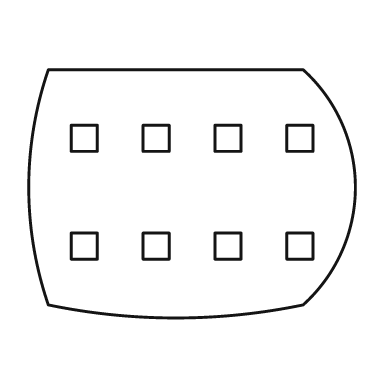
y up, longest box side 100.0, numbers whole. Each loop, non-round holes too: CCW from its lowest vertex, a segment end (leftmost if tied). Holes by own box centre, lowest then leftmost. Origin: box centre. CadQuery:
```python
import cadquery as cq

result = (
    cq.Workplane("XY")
    .moveTo(-44.0, -34.0)
    .threePointArc((-5.0, -38.0), (34.0, -34.0))
    .threePointArc((50.0, 2.0), (34.0, 38.0))
    .lineTo(-44.0, 38.0)
    .threePointArc((-50.0, 2.0), (-44.0, -34.0))
    .close()
    .moveTo(-37.0, -20.0)
    .lineTo(-29.0, -20.0)
    .lineTo(-29.0, -12.0)
    .lineTo(-37.0, -12.0)
    .close()
    .moveTo(-15.0, -20.0)
    .lineTo(-7.0, -20.0)
    .lineTo(-7.0, -12.0)
    .lineTo(-15.0, -12.0)
    .close()
    .moveTo(7.0, -20.0)
    .lineTo(15.0, -20.0)
    .lineTo(15.0, -12.0)
    .lineTo(7.0, -12.0)
    .close()
    .moveTo(29.0, -20.0)
    .lineTo(37.0, -20.0)
    .lineTo(37.0, -12.0)
    .lineTo(29.0, -12.0)
    .close()
    .moveTo(-37.0, 13.0)
    .lineTo(-29.0, 13.0)
    .lineTo(-29.0, 21.0)
    .lineTo(-37.0, 21.0)
    .close()
    .moveTo(-15.0, 13.0)
    .lineTo(-7.0, 13.0)
    .lineTo(-7.0, 21.0)
    .lineTo(-15.0, 21.0)
    .close()
    .moveTo(7.0, 13.0)
    .lineTo(15.0, 13.0)
    .lineTo(15.0, 21.0)
    .lineTo(7.0, 21.0)
    .close()
    .moveTo(29.0, 13.0)
    .lineTo(37.0, 13.0)
    .lineTo(37.0, 21.0)
    .lineTo(29.0, 21.0)
    .close()
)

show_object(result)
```